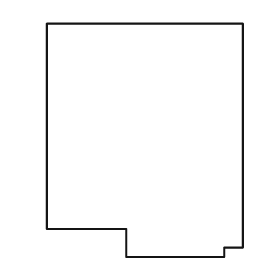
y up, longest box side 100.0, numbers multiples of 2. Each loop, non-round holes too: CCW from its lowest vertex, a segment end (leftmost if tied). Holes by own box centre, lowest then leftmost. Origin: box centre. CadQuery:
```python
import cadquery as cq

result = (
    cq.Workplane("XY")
    .moveTo(-8.0, -50.0)
    .lineTo(34.0, -50.0)
    .lineTo(34.0, -46.0)
    .lineTo(42.0, -46.0)
    .lineTo(42.0, 50.0)
    .lineTo(-42.0, 50.0)
    .lineTo(-42.0, -38.0)
    .lineTo(-8.0, -38.0)
    .close()
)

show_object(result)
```